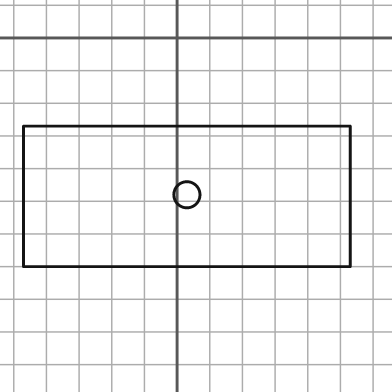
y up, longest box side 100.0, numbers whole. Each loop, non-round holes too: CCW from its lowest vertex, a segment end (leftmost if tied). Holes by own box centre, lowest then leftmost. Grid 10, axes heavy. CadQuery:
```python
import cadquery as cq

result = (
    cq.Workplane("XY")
    .moveTo(-47.0, -70.0)
    .lineTo(53.0, -70.0)
    .lineTo(53.0, -27.0)
    .lineTo(-47.0, -27.0)
    .close()
    .moveTo(3.0, -48.0)
    .circle(4.0)
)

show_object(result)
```